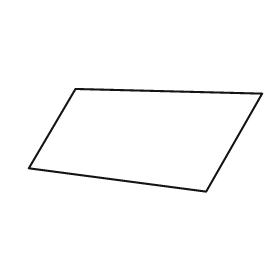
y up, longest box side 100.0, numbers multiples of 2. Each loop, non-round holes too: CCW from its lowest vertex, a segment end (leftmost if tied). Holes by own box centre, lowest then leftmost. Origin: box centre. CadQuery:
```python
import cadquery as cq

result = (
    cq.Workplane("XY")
    .moveTo(26.0, -22.0)
    .lineTo(50.0, 20.0)
    .lineTo(-30.0, 22.0)
    .lineTo(-50.0, -12.0)
    .close()
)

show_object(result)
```